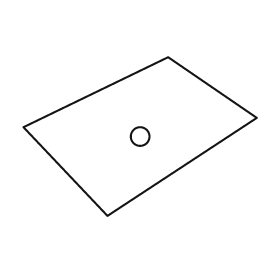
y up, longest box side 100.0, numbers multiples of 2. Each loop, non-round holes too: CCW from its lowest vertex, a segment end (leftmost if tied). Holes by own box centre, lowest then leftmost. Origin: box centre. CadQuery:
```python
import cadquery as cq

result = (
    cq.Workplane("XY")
    .moveTo(-14.0, -34.0)
    .lineTo(50.0, 8.0)
    .lineTo(12.0, 34.0)
    .lineTo(-50.0, 4.0)
    .close()
    .moveTo(0.0, 0.0)
    .circle(4.0)
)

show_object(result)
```